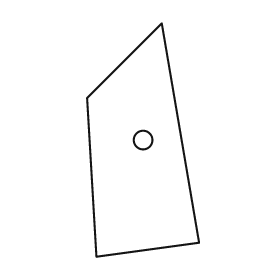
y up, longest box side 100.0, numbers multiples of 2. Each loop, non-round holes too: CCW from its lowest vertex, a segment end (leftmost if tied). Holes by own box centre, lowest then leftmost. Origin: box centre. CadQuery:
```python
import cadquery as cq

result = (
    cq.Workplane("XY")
    .moveTo(-20.0, -50.0)
    .lineTo(24.0, -44.0)
    .lineTo(8.0, 50.0)
    .lineTo(-24.0, 18.0)
    .close()
    .moveTo(0.0, 0.0)
    .circle(4.0)
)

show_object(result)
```